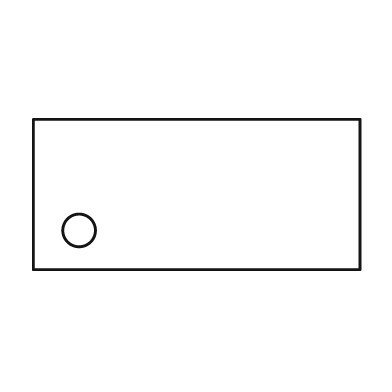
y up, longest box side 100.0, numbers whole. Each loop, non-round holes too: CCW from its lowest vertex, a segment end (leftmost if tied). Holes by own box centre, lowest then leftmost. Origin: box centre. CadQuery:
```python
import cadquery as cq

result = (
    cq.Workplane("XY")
    .moveTo(-50.0, -23.0)
    .lineTo(50.0, -23.0)
    .lineTo(50.0, 23.0)
    .lineTo(-50.0, 23.0)
    .close()
    .moveTo(-36.0, -11.0)
    .circle(5.0)
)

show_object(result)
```